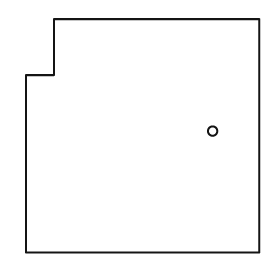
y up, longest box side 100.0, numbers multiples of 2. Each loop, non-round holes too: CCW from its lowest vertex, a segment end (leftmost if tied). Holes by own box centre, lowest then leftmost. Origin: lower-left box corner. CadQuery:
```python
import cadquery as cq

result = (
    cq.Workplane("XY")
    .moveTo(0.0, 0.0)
    .lineTo(100.0, 0.0)
    .lineTo(100.0, 100.0)
    .lineTo(12.0, 100.0)
    .lineTo(12.0, 76.0)
    .lineTo(0.0, 76.0)
    .close()
    .moveTo(80.0, 52.0)
    .circle(2.0)
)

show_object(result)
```